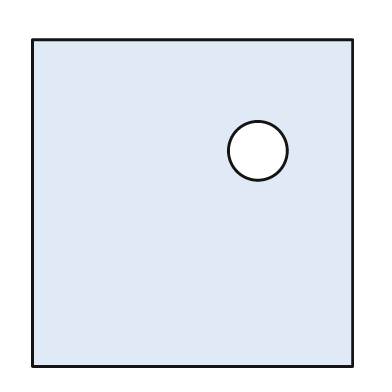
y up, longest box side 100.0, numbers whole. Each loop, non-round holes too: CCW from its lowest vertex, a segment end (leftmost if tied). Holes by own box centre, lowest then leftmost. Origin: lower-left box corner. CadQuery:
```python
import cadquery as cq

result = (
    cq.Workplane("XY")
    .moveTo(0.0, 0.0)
    .lineTo(98.0, 0.0)
    .lineTo(98.0, 100.0)
    .lineTo(0.0, 100.0)
    .close()
    .moveTo(69.0, 66.0)
    .circle(9.0)
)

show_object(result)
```